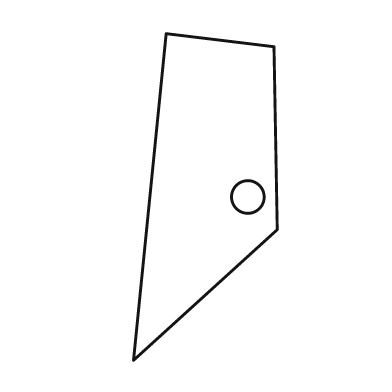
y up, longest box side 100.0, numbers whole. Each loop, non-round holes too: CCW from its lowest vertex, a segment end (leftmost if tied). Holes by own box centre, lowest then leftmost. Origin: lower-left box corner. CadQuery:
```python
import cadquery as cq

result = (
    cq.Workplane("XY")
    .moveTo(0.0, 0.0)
    .lineTo(44.0, 40.0)
    .lineTo(43.0, 96.0)
    .lineTo(10.0, 100.0)
    .close()
    .moveTo(35.0, 50.0)
    .circle(5.0)
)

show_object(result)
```